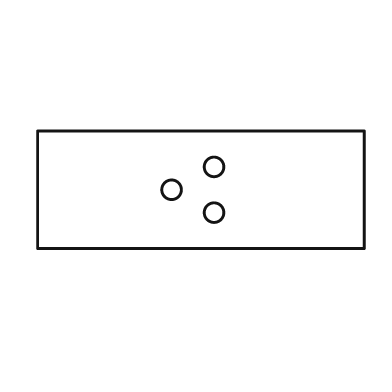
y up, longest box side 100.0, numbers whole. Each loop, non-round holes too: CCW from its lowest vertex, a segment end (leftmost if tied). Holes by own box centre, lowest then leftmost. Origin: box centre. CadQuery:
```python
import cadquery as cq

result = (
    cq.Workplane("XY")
    .moveTo(-50.0, -18.0)
    .lineTo(50.0, -18.0)
    .lineTo(50.0, 18.0)
    .lineTo(-50.0, 18.0)
    .close()
    .moveTo(4.0, -7.0)
    .circle(3.0)
    .moveTo(-9.0, 0.0)
    .circle(3.0)
    .moveTo(4.0, 7.0)
    .circle(3.0)
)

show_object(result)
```